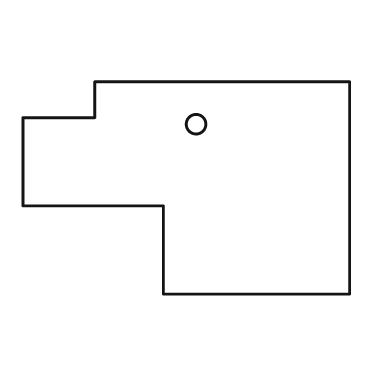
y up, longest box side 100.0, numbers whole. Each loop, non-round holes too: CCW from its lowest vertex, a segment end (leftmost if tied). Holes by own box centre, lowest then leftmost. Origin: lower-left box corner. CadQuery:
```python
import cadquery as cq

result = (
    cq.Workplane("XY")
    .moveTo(43.0, 0.0)
    .lineTo(100.0, 0.0)
    .lineTo(100.0, 65.0)
    .lineTo(22.0, 65.0)
    .lineTo(22.0, 54.0)
    .lineTo(0.0, 54.0)
    .lineTo(0.0, 27.0)
    .lineTo(43.0, 27.0)
    .close()
    .moveTo(53.0, 52.0)
    .circle(3.0)
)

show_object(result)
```